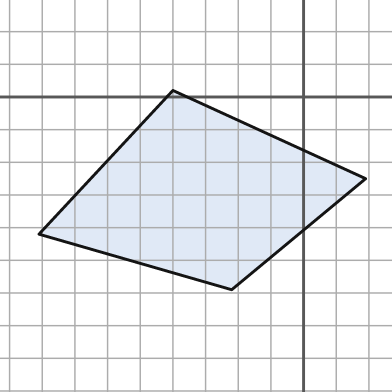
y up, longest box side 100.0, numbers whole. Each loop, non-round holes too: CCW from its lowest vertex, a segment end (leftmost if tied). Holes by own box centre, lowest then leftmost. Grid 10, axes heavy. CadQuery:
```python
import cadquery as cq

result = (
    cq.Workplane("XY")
    .moveTo(-22.0, -59.0)
    .lineTo(19.0, -25.0)
    .lineTo(-40.0, 2.0)
    .lineTo(-81.0, -42.0)
    .close()
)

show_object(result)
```